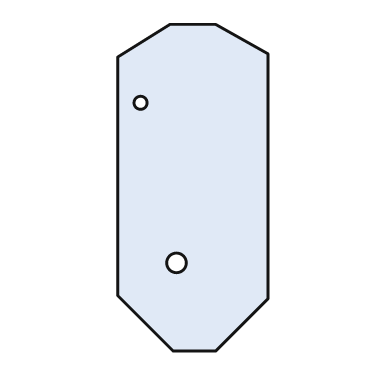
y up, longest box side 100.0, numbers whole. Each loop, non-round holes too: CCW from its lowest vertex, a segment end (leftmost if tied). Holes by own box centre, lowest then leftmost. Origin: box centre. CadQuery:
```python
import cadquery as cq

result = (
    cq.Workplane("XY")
    .moveTo(-6.0, -50.0)
    .lineTo(7.0, -50.0)
    .lineTo(23.0, -34.0)
    .lineTo(23.0, 41.0)
    .lineTo(7.0, 50.0)
    .lineTo(-7.0, 50.0)
    .lineTo(-23.0, 40.0)
    .lineTo(-23.0, -33.0)
    .close()
    .moveTo(-5.0, -23.0)
    .circle(3.0)
    .moveTo(-16.0, 26.0)
    .circle(2.0)
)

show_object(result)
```